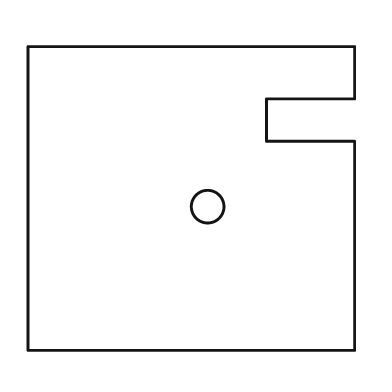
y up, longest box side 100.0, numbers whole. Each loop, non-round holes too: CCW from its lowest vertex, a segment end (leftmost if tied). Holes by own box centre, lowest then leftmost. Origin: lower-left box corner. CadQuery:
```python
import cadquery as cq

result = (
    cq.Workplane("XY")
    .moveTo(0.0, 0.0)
    .lineTo(100.0, 0.0)
    .lineTo(100.0, 64.0)
    .lineTo(73.0, 64.0)
    .lineTo(73.0, 77.0)
    .lineTo(100.0, 77.0)
    .lineTo(100.0, 93.0)
    .lineTo(0.0, 93.0)
    .close()
    .moveTo(55.0, 44.0)
    .circle(5.0)
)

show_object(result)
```